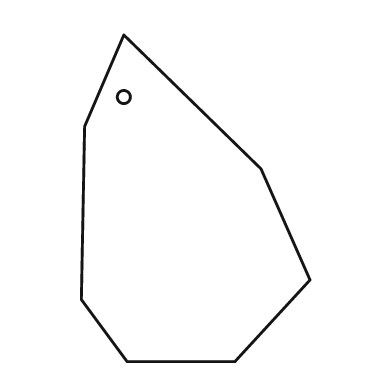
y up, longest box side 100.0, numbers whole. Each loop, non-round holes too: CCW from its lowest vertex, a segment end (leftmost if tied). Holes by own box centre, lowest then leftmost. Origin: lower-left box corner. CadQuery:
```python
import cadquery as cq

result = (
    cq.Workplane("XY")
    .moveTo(14.0, 0.0)
    .lineTo(47.0, 0.0)
    .lineTo(70.0, 25.0)
    .lineTo(55.0, 59.0)
    .lineTo(13.0, 100.0)
    .lineTo(1.0, 72.0)
    .lineTo(0.0, 19.0)
    .close()
    .moveTo(13.0, 81.0)
    .circle(2.0)
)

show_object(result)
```